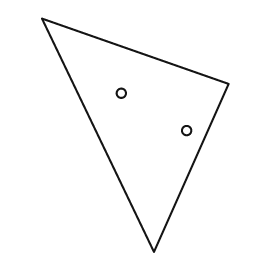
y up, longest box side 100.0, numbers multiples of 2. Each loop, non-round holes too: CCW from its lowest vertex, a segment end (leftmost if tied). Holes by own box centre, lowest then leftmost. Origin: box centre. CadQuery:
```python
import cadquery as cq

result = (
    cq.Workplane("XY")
    .moveTo(8.0, -50.0)
    .lineTo(40.0, 22.0)
    .lineTo(-40.0, 50.0)
    .close()
    .moveTo(22.0, 2.0)
    .circle(2.0)
    .moveTo(-6.0, 18.0)
    .circle(2.0)
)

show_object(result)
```